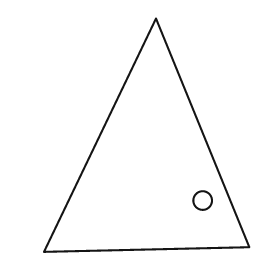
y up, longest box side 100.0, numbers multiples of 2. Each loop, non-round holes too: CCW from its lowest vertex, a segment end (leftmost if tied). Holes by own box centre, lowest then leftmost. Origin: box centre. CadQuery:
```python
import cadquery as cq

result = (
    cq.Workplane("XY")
    .moveTo(-44.0, -50.0)
    .lineTo(44.0, -48.0)
    .lineTo(4.0, 50.0)
    .close()
    .moveTo(24.0, -28.0)
    .circle(4.0)
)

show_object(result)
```